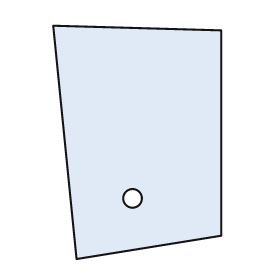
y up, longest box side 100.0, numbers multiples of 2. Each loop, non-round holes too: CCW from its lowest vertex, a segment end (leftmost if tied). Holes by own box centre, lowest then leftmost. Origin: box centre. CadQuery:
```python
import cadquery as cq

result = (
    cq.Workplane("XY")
    .moveTo(-26.0, -50.0)
    .lineTo(36.0, -40.0)
    .lineTo(36.0, 48.0)
    .lineTo(-36.0, 50.0)
    .close()
    .moveTo(-2.0, -24.0)
    .circle(4.0)
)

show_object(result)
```